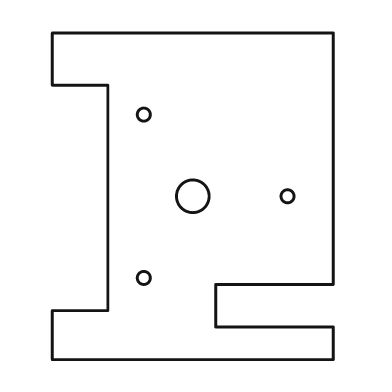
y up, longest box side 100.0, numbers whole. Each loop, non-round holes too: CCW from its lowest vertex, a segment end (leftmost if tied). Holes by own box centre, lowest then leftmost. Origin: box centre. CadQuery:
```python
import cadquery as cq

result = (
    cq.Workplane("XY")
    .moveTo(-43.0, -50.0)
    .lineTo(43.0, -50.0)
    .lineTo(43.0, -40.0)
    .lineTo(7.0, -40.0)
    .lineTo(7.0, -27.0)
    .lineTo(43.0, -27.0)
    .lineTo(43.0, 50.0)
    .lineTo(-43.0, 50.0)
    .lineTo(-43.0, 34.0)
    .lineTo(-26.0, 34.0)
    .lineTo(-26.0, -35.0)
    .lineTo(-43.0, -35.0)
    .close()
    .moveTo(-15.0, -25.0)
    .circle(2.0)
    .moveTo(0.0, 0.0)
    .circle(5.0)
    .moveTo(29.0, 0.0)
    .circle(2.0)
    .moveTo(-15.0, 25.0)
    .circle(2.0)
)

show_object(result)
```